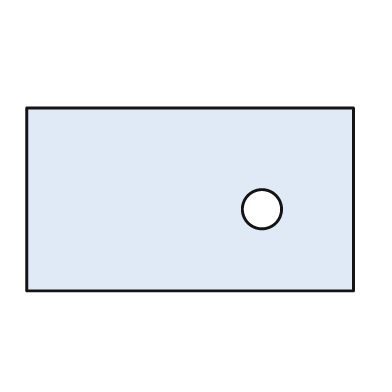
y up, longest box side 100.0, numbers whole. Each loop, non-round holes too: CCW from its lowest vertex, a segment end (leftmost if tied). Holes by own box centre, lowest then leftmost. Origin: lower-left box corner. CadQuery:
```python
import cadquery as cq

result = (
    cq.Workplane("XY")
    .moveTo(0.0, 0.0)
    .lineTo(100.0, 0.0)
    .lineTo(100.0, 56.0)
    .lineTo(0.0, 56.0)
    .close()
    .moveTo(72.0, 25.0)
    .circle(6.0)
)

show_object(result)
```